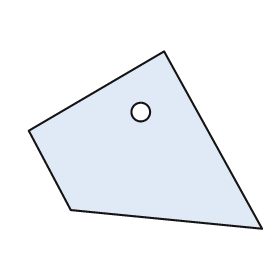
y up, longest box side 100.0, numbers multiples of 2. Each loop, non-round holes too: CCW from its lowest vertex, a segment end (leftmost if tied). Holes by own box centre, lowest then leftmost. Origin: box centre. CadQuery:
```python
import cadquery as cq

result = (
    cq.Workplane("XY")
    .moveTo(50.0, -38.0)
    .lineTo(8.0, 38.0)
    .lineTo(-50.0, 4.0)
    .lineTo(-32.0, -30.0)
    .close()
    .moveTo(-2.0, 12.0)
    .circle(4.0)
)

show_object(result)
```